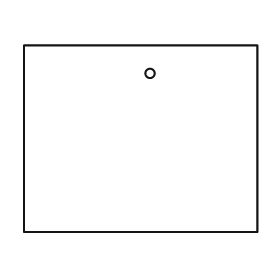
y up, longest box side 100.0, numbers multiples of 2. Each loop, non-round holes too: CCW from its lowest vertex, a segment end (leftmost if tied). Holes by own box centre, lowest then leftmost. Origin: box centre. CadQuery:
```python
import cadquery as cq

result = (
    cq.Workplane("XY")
    .moveTo(-50.0, -40.0)
    .lineTo(50.0, -40.0)
    .lineTo(50.0, 40.0)
    .lineTo(-50.0, 40.0)
    .close()
    .moveTo(4.0, 28.0)
    .circle(2.0)
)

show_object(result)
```